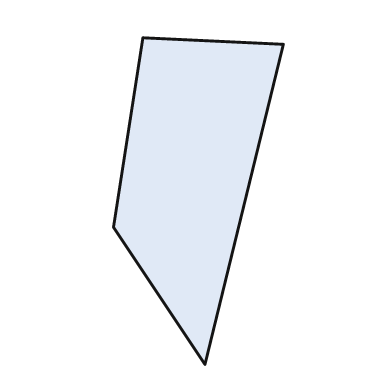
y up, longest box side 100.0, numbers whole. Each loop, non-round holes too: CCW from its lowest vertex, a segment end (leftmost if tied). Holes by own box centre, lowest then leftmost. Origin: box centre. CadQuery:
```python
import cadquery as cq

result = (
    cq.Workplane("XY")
    .moveTo(2.0, -50.0)
    .lineTo(26.0, 48.0)
    .lineTo(-17.0, 50.0)
    .lineTo(-26.0, -8.0)
    .close()
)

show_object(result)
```